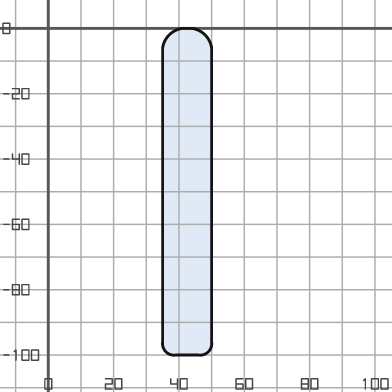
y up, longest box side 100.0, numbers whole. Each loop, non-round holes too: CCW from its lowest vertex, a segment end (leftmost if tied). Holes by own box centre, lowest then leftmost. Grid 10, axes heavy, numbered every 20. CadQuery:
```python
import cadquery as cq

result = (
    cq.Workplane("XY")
    .moveTo(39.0, -100.0)
    .lineTo(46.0, -100.0)
    .threePointArc((49.0, -99.0), (50.0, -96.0))
    .lineTo(50.0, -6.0)
    .threePointArc((48.0, -2.0), (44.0, 0.0))
    .lineTo(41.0, 0.0)
    .threePointArc((37.0, -2.0), (35.0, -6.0))
    .lineTo(35.0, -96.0)
    .threePointArc((36.0, -99.0), (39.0, -100.0))
    .close()
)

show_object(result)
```